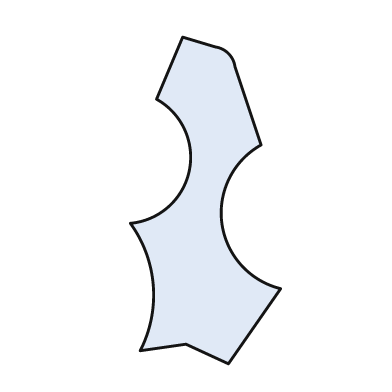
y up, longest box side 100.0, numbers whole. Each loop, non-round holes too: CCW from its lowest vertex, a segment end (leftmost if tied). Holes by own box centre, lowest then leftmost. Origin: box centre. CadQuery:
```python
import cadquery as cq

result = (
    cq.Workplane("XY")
    .moveTo(7.0, -50.0)
    .lineTo(23.0, -27.0)
    .threePointArc((5.0, -7.0), (17.0, 17.0))
    .lineTo(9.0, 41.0)
    .threePointArc((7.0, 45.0), (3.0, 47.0))
    .lineTo(-7.0, 50.0)
    .lineTo(-15.0, 31.0)
    .threePointArc((-5.0, 9.0), (-23.0, -7.0))
    .threePointArc((-16.0, -26.0), (-20.0, -46.0))
    .lineTo(-6.0, -44.0)
    .close()
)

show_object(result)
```